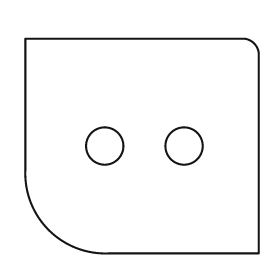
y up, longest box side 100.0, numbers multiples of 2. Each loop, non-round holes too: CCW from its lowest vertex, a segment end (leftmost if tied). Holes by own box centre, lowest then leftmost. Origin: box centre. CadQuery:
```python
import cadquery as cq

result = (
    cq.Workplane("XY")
    .moveTo(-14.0, -46.0)
    .lineTo(50.0, -46.0)
    .lineTo(50.0, 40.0)
    .threePointArc((48.0, 44.0), (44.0, 46.0))
    .lineTo(-50.0, 46.0)
    .lineTo(-50.0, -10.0)
    .threePointArc((-40.0, -36.0), (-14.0, -46.0))
    .close()
    .moveTo(-16.0, 0.0)
    .circle(8.0)
    .moveTo(18.0, 0.0)
    .circle(8.0)
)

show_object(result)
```